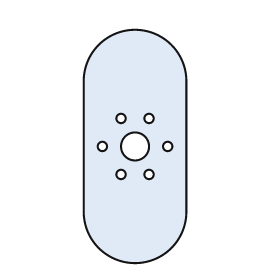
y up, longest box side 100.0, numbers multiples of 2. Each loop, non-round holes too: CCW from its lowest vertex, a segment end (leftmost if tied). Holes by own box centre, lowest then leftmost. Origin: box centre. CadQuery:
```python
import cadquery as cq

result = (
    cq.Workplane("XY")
    .moveTo(-22.0, -28.0)
    .threePointArc((0.0, -50.0), (22.0, -28.0))
    .lineTo(22.0, 28.0)
    .threePointArc((0.0, 50.0), (-22.0, 28.0))
    .close()
    .moveTo(-6.0, -12.0)
    .circle(2.0)
    .moveTo(6.0, -12.0)
    .circle(2.0)
    .moveTo(-14.0, 0.0)
    .circle(2.0)
    .moveTo(0.0, 0.0)
    .circle(6.0)
    .moveTo(14.0, 0.0)
    .circle(2.0)
    .moveTo(-6.0, 12.0)
    .circle(2.0)
    .moveTo(6.0, 12.0)
    .circle(2.0)
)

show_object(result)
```